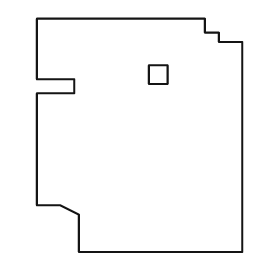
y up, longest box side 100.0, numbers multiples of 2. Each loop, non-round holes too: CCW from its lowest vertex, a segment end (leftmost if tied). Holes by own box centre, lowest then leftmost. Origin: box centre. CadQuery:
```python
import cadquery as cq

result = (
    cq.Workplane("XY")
    .moveTo(-26.0, -50.0)
    .lineTo(44.0, -50.0)
    .lineTo(44.0, 40.0)
    .lineTo(34.0, 40.0)
    .lineTo(34.0, 44.0)
    .lineTo(28.0, 44.0)
    .lineTo(28.0, 50.0)
    .lineTo(-44.0, 50.0)
    .lineTo(-44.0, 24.0)
    .lineTo(-28.0, 24.0)
    .lineTo(-28.0, 18.0)
    .lineTo(-44.0, 18.0)
    .lineTo(-44.0, -30.0)
    .lineTo(-34.0, -30.0)
    .lineTo(-26.0, -34.0)
    .close()
    .moveTo(4.0, 22.0)
    .lineTo(12.0, 22.0)
    .lineTo(12.0, 30.0)
    .lineTo(4.0, 30.0)
    .close()
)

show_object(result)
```